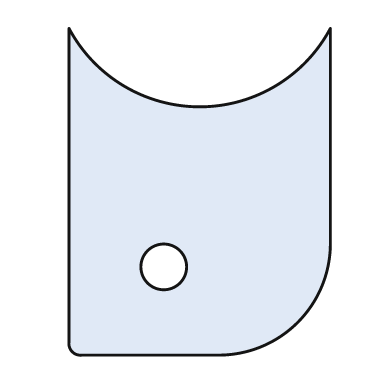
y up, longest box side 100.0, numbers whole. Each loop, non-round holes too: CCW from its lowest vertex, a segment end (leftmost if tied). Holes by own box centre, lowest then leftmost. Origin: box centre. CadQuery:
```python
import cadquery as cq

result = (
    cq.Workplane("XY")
    .moveTo(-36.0, -50.0)
    .lineTo(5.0, -50.0)
    .threePointArc((30.0, -40.0), (40.0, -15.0))
    .lineTo(40.0, 50.0)
    .threePointArc((0.0, 26.0), (-40.0, 50.0))
    .lineTo(-40.0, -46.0)
    .threePointArc((-39.0, -49.0), (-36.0, -50.0))
    .close()
    .moveTo(-11.0, -23.0)
    .circle(7.0)
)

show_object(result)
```